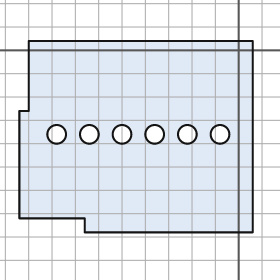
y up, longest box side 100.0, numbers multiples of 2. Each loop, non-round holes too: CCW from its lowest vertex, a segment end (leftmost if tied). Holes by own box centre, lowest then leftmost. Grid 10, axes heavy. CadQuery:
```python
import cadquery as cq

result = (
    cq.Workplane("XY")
    .moveTo(-66.0, -78.0)
    .lineTo(6.0, -78.0)
    .lineTo(6.0, 4.0)
    .lineTo(-90.0, 4.0)
    .lineTo(-90.0, -26.0)
    .lineTo(-94.0, -26.0)
    .lineTo(-94.0, -72.0)
    .lineTo(-66.0, -72.0)
    .close()
    .moveTo(-78.0, -36.0)
    .circle(4.0)
    .moveTo(-64.0, -36.0)
    .circle(4.0)
    .moveTo(-50.0, -36.0)
    .circle(4.0)
    .moveTo(-36.0, -36.0)
    .circle(4.0)
    .moveTo(-22.0, -36.0)
    .circle(4.0)
    .moveTo(-8.0, -36.0)
    .circle(4.0)
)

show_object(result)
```